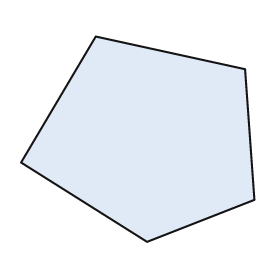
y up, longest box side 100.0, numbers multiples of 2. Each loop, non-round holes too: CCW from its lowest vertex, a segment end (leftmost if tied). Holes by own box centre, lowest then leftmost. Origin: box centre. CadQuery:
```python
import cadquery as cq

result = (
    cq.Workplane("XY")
    .moveTo(4.0, -44.0)
    .lineTo(50.0, -26.0)
    .lineTo(46.0, 30.0)
    .lineTo(-18.0, 44.0)
    .lineTo(-50.0, -10.0)
    .close()
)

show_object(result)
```